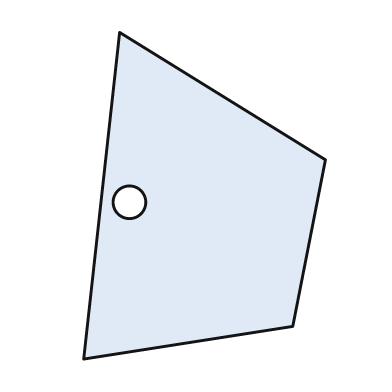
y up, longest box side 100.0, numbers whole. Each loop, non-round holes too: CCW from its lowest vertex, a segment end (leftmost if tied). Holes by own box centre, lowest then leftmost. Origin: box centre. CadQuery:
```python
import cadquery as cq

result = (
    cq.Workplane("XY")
    .moveTo(-37.0, -50.0)
    .lineTo(27.0, -40.0)
    .lineTo(37.0, 11.0)
    .lineTo(-26.0, 50.0)
    .close()
    .moveTo(-23.0, -2.0)
    .circle(5.0)
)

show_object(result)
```